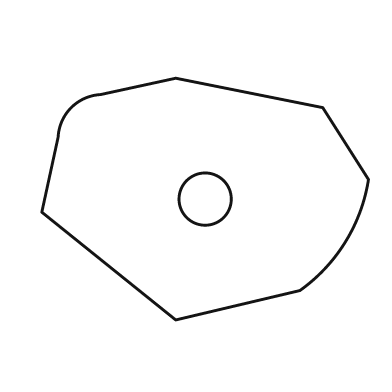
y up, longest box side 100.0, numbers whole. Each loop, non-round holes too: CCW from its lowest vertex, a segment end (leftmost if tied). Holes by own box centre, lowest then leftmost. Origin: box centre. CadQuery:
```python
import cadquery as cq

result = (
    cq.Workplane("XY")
    .moveTo(-9.0, -37.0)
    .lineTo(29.0, -28.0)
    .threePointArc((43.0, -13.0), (50.0, 6.0))
    .lineTo(36.0, 28.0)
    .lineTo(-9.0, 37.0)
    .lineTo(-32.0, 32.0)
    .threePointArc((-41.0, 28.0), (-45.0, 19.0))
    .lineTo(-50.0, -4.0)
    .close()
    .moveTo(0.0, 0.0)
    .circle(8.0)
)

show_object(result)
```